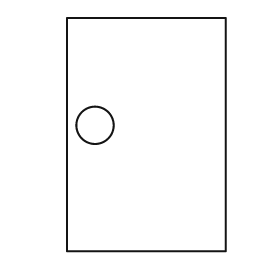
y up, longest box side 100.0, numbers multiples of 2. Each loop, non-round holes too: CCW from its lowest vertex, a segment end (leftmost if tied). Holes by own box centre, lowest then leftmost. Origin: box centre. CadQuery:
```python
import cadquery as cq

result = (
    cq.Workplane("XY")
    .moveTo(-34.0, -50.0)
    .lineTo(34.0, -50.0)
    .lineTo(34.0, 50.0)
    .lineTo(-34.0, 50.0)
    .close()
    .moveTo(-22.0, 4.0)
    .circle(8.0)
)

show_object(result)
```